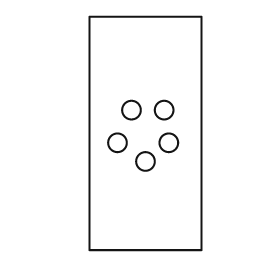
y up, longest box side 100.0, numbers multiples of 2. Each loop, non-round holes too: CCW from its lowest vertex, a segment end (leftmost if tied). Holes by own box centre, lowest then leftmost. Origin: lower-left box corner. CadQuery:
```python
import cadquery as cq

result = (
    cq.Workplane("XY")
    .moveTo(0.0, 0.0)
    .lineTo(48.0, 0.0)
    .lineTo(48.0, 100.0)
    .lineTo(0.0, 100.0)
    .close()
    .moveTo(24.0, 38.0)
    .circle(4.0)
    .moveTo(12.0, 46.0)
    .circle(4.0)
    .moveTo(34.0, 46.0)
    .circle(4.0)
    .moveTo(18.0, 60.0)
    .circle(4.0)
    .moveTo(32.0, 60.0)
    .circle(4.0)
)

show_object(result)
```